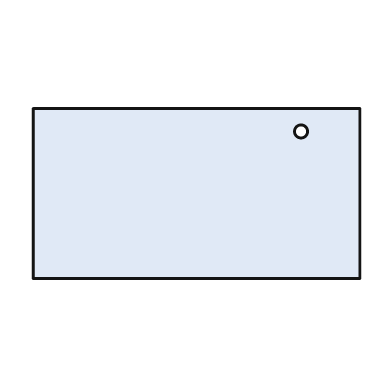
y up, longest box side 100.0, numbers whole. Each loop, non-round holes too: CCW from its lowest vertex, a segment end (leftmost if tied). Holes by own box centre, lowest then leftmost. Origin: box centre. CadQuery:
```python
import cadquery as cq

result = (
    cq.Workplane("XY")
    .moveTo(-50.0, -26.0)
    .lineTo(50.0, -26.0)
    .lineTo(50.0, 26.0)
    .lineTo(-50.0, 26.0)
    .close()
    .moveTo(32.0, 19.0)
    .circle(2.0)
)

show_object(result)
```